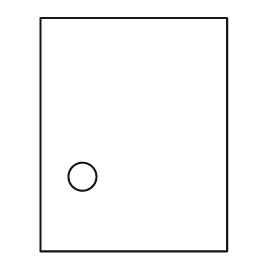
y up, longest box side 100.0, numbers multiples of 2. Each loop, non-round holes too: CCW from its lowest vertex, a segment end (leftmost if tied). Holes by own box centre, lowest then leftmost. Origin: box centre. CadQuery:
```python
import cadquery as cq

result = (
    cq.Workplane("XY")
    .moveTo(-40.0, -50.0)
    .lineTo(40.0, -50.0)
    .lineTo(40.0, 50.0)
    .lineTo(-40.0, 50.0)
    .close()
    .moveTo(-22.0, -18.0)
    .circle(6.0)
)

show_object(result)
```